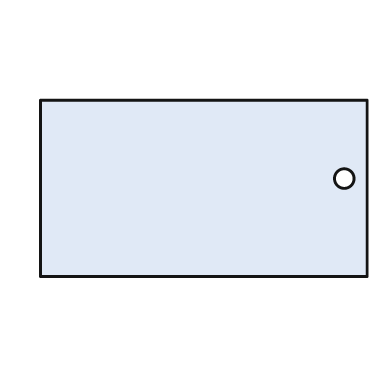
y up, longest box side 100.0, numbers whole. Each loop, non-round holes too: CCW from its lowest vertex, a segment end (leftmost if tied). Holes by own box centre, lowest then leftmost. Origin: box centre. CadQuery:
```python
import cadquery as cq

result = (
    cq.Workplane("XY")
    .moveTo(-50.0, -27.0)
    .lineTo(50.0, -27.0)
    .lineTo(50.0, 27.0)
    .lineTo(-50.0, 27.0)
    .close()
    .moveTo(43.0, 3.0)
    .circle(3.0)
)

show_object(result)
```